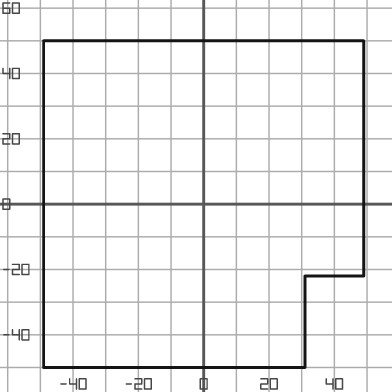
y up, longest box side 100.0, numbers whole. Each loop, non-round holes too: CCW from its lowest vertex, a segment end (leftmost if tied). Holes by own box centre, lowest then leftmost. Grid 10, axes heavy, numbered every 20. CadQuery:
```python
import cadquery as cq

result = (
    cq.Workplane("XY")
    .moveTo(-49.0, -50.0)
    .lineTo(31.0, -50.0)
    .lineTo(31.0, -22.0)
    .lineTo(49.0, -22.0)
    .lineTo(49.0, 50.0)
    .lineTo(-49.0, 50.0)
    .close()
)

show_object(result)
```